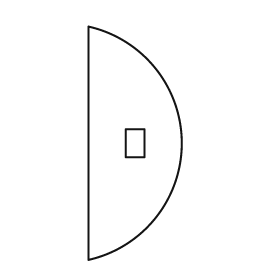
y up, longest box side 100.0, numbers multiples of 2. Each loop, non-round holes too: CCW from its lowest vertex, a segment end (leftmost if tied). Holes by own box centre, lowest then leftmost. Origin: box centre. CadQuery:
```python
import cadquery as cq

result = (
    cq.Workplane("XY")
    .moveTo(-20.0, -50.0)
    .threePointArc((20.0, 0.0), (-20.0, 50.0))
    .close()
    .moveTo(-4.0, -6.0)
    .lineTo(4.0, -6.0)
    .lineTo(4.0, 6.0)
    .lineTo(-4.0, 6.0)
    .close()
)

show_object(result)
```